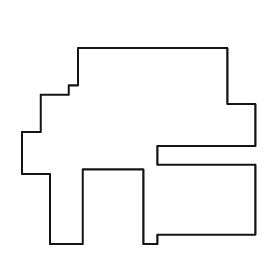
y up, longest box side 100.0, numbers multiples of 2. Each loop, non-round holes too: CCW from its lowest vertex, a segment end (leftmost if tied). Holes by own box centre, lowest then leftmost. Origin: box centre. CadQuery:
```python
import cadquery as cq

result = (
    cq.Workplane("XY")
    .moveTo(-38.0, -42.0)
    .lineTo(-24.0, -42.0)
    .lineTo(-24.0, -10.0)
    .lineTo(2.0, -10.0)
    .lineTo(2.0, -42.0)
    .lineTo(8.0, -42.0)
    .lineTo(8.0, -38.0)
    .lineTo(50.0, -38.0)
    .lineTo(50.0, -8.0)
    .lineTo(8.0, -8.0)
    .lineTo(8.0, 0.0)
    .lineTo(50.0, 0.0)
    .lineTo(50.0, 18.0)
    .lineTo(38.0, 18.0)
    .lineTo(38.0, 42.0)
    .lineTo(-26.0, 42.0)
    .lineTo(-26.0, 26.0)
    .lineTo(-30.0, 26.0)
    .lineTo(-30.0, 22.0)
    .lineTo(-42.0, 22.0)
    .lineTo(-42.0, 6.0)
    .lineTo(-50.0, 6.0)
    .lineTo(-50.0, -12.0)
    .lineTo(-38.0, -12.0)
    .close()
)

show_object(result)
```